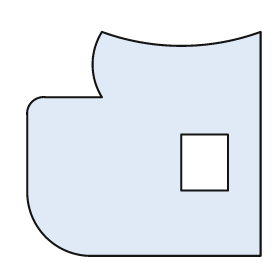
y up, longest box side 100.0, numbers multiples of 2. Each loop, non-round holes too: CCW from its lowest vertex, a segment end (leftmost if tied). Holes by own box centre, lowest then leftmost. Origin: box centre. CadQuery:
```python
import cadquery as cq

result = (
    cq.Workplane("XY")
    .moveTo(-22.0, -48.0)
    .lineTo(50.0, -48.0)
    .lineTo(50.0, 48.0)
    .threePointArc((16.0, 42.0), (-18.0, 48.0))
    .threePointArc((-22.0, 34.0), (-18.0, 20.0))
    .lineTo(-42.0, 20.0)
    .threePointArc((-48.0, 18.0), (-50.0, 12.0))
    .lineTo(-50.0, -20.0)
    .threePointArc((-42.0, -40.0), (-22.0, -48.0))
    .close()
    .moveTo(16.0, -20.0)
    .lineTo(36.0, -20.0)
    .lineTo(36.0, 4.0)
    .lineTo(16.0, 4.0)
    .close()
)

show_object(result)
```